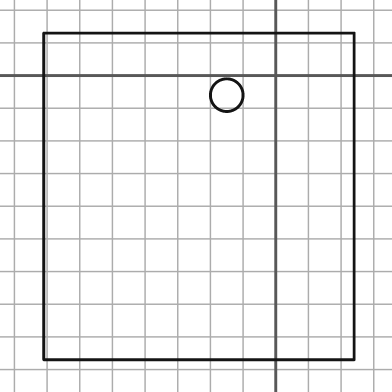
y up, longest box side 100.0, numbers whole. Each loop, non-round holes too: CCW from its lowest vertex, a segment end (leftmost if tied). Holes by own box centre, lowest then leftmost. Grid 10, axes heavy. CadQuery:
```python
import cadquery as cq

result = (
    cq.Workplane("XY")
    .moveTo(-71.0, -87.0)
    .lineTo(24.0, -87.0)
    .lineTo(24.0, 13.0)
    .lineTo(-71.0, 13.0)
    .close()
    .moveTo(-15.0, -6.0)
    .circle(5.0)
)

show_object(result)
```